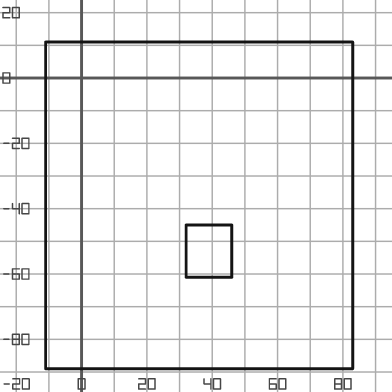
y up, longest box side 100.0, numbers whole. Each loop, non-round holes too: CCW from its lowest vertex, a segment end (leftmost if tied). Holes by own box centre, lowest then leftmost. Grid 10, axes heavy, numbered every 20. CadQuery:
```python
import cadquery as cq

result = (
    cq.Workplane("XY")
    .moveTo(-11.0, -89.0)
    .lineTo(83.0, -89.0)
    .lineTo(83.0, 11.0)
    .lineTo(-11.0, 11.0)
    .close()
    .moveTo(32.0, -61.0)
    .lineTo(46.0, -61.0)
    .lineTo(46.0, -45.0)
    .lineTo(32.0, -45.0)
    .close()
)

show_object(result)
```